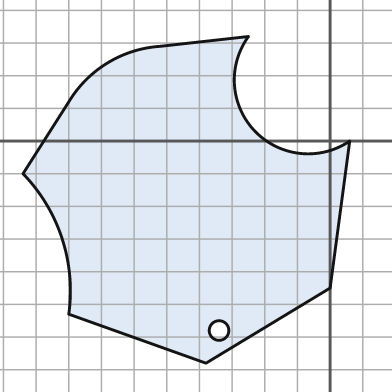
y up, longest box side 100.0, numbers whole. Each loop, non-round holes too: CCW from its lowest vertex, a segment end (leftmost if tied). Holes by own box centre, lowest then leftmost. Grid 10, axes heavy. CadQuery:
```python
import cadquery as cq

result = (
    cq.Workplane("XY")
    .moveTo(-38.0, -68.0)
    .lineTo(0.0, -45.0)
    .lineTo(6.0, 0.0)
    .threePointArc((-23.0, 3.0), (-25.0, 32.0))
    .lineTo(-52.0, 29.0)
    .threePointArc((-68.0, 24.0), (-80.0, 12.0))
    .lineTo(-94.0, -10.0)
    .threePointArc((-82.0, -30.0), (-80.0, -53.0))
    .close()
    .moveTo(-34.0, -58.0)
    .circle(3.0)
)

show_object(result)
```